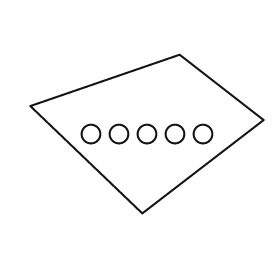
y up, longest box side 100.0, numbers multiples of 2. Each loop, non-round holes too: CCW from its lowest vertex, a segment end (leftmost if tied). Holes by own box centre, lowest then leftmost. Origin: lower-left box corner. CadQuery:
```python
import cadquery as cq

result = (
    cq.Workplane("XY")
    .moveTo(48.0, 0.0)
    .lineTo(100.0, 40.0)
    .lineTo(64.0, 68.0)
    .lineTo(0.0, 46.0)
    .close()
    .moveTo(26.0, 34.0)
    .circle(4.0)
    .moveTo(38.0, 34.0)
    .circle(4.0)
    .moveTo(50.0, 34.0)
    .circle(4.0)
    .moveTo(62.0, 34.0)
    .circle(4.0)
    .moveTo(74.0, 34.0)
    .circle(4.0)
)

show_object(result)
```